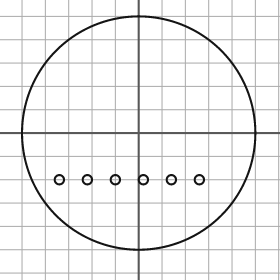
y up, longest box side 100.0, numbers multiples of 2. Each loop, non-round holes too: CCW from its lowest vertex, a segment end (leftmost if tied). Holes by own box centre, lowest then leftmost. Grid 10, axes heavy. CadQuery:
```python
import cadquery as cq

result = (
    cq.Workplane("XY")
    .moveTo(0.0, 0.0)
    .circle(50.0)
    .moveTo(-34.0, -20.0)
    .circle(2.0)
    .moveTo(-22.0, -20.0)
    .circle(2.0)
    .moveTo(-10.0, -20.0)
    .circle(2.0)
    .moveTo(2.0, -20.0)
    .circle(2.0)
    .moveTo(14.0, -20.0)
    .circle(2.0)
    .moveTo(26.0, -20.0)
    .circle(2.0)
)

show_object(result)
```